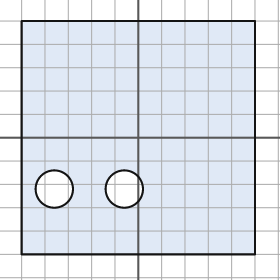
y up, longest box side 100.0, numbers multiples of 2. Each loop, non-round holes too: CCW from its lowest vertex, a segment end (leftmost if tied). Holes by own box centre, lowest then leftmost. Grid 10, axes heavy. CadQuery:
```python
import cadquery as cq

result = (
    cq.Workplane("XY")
    .moveTo(-50.0, -50.0)
    .lineTo(50.0, -50.0)
    .lineTo(50.0, 50.0)
    .lineTo(-50.0, 50.0)
    .close()
    .moveTo(-36.0, -22.0)
    .circle(8.0)
    .moveTo(-6.0, -22.0)
    .circle(8.0)
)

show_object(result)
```